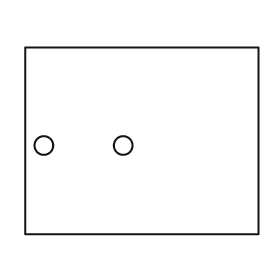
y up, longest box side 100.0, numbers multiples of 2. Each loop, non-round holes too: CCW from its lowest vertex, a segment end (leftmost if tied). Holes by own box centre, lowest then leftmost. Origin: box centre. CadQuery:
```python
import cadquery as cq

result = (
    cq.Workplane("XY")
    .moveTo(-50.0, -40.0)
    .lineTo(50.0, -40.0)
    .lineTo(50.0, 40.0)
    .lineTo(-50.0, 40.0)
    .close()
    .moveTo(-42.0, -2.0)
    .circle(4.0)
    .moveTo(-8.0, -2.0)
    .circle(4.0)
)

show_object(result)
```